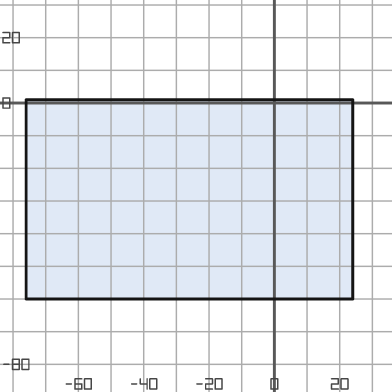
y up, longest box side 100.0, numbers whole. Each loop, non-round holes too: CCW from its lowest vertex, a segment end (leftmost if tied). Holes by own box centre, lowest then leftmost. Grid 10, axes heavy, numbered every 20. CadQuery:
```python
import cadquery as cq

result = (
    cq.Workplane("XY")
    .moveTo(-76.0, -60.0)
    .lineTo(24.0, -60.0)
    .lineTo(24.0, 1.0)
    .lineTo(-76.0, 1.0)
    .close()
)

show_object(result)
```